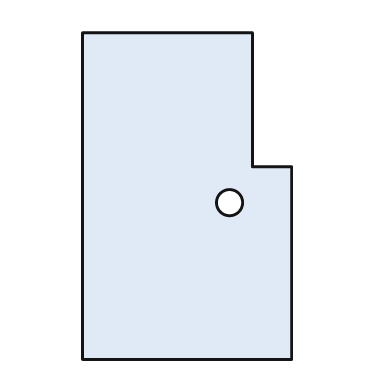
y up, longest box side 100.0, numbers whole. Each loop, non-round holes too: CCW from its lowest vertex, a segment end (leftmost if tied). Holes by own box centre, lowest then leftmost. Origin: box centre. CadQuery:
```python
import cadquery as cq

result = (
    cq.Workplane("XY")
    .moveTo(-32.0, -50.0)
    .lineTo(32.0, -50.0)
    .lineTo(32.0, 9.0)
    .lineTo(20.0, 9.0)
    .lineTo(20.0, 50.0)
    .lineTo(-32.0, 50.0)
    .close()
    .moveTo(13.0, -2.0)
    .circle(4.0)
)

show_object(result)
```